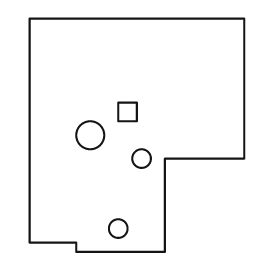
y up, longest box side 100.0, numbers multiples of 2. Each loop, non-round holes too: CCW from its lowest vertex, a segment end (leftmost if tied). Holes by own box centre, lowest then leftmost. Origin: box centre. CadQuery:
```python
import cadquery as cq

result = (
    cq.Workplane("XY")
    .moveTo(-26.0, -50.0)
    .lineTo(12.0, -50.0)
    .lineTo(12.0, -10.0)
    .lineTo(46.0, -10.0)
    .lineTo(46.0, 50.0)
    .lineTo(-46.0, 50.0)
    .lineTo(-46.0, -46.0)
    .lineTo(-26.0, -46.0)
    .close()
    .moveTo(-8.0, -40.0)
    .circle(4.0)
    .moveTo(2.0, -10.0)
    .circle(4.0)
    .moveTo(-20.0, 0.0)
    .circle(6.0)
    .moveTo(-8.0, 6.0)
    .lineTo(0.0, 6.0)
    .lineTo(0.0, 14.0)
    .lineTo(-8.0, 14.0)
    .close()
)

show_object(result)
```